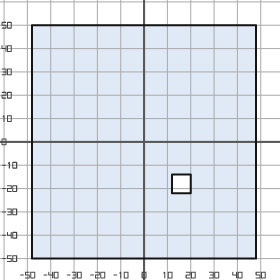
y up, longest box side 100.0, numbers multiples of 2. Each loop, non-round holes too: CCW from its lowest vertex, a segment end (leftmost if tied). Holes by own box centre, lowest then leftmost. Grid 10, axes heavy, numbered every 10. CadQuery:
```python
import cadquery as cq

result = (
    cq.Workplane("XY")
    .moveTo(-48.0, -50.0)
    .lineTo(48.0, -50.0)
    .lineTo(48.0, 50.0)
    .lineTo(-48.0, 50.0)
    .close()
    .moveTo(12.0, -22.0)
    .lineTo(20.0, -22.0)
    .lineTo(20.0, -14.0)
    .lineTo(12.0, -14.0)
    .close()
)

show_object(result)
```